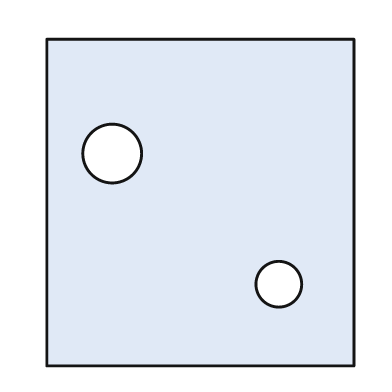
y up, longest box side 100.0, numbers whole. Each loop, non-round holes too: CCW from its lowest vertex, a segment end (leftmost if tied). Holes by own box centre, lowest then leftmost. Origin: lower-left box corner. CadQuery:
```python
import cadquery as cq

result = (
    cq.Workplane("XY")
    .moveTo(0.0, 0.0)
    .lineTo(94.0, 0.0)
    .lineTo(94.0, 100.0)
    .lineTo(0.0, 100.0)
    .close()
    .moveTo(71.0, 25.0)
    .circle(7.0)
    .moveTo(20.0, 65.0)
    .circle(9.0)
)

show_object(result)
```